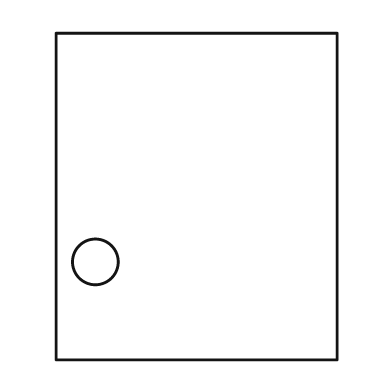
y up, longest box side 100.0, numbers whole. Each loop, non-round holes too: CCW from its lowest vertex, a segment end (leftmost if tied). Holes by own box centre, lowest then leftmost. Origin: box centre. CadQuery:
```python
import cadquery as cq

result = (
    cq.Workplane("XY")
    .moveTo(-43.0, -50.0)
    .lineTo(43.0, -50.0)
    .lineTo(43.0, 50.0)
    .lineTo(-43.0, 50.0)
    .close()
    .moveTo(-31.0, -20.0)
    .circle(7.0)
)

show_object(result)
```